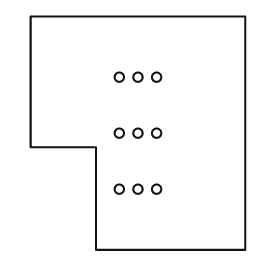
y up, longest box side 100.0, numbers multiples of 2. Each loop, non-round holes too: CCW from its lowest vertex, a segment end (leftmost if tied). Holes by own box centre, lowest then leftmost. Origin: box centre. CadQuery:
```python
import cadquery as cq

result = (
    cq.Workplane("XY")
    .moveTo(-18.0, -50.0)
    .lineTo(46.0, -50.0)
    .lineTo(46.0, 50.0)
    .lineTo(-46.0, 50.0)
    .lineTo(-46.0, -6.0)
    .lineTo(-18.0, -6.0)
    .close()
    .moveTo(-8.0, -24.0)
    .circle(2.0)
    .moveTo(0.0, -24.0)
    .circle(2.0)
    .moveTo(8.0, -24.0)
    .circle(2.0)
    .moveTo(-8.0, 0.0)
    .circle(2.0)
    .moveTo(0.0, 0.0)
    .circle(2.0)
    .moveTo(8.0, 0.0)
    .circle(2.0)
    .moveTo(-8.0, 24.0)
    .circle(2.0)
    .moveTo(0.0, 24.0)
    .circle(2.0)
    .moveTo(8.0, 24.0)
    .circle(2.0)
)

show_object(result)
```